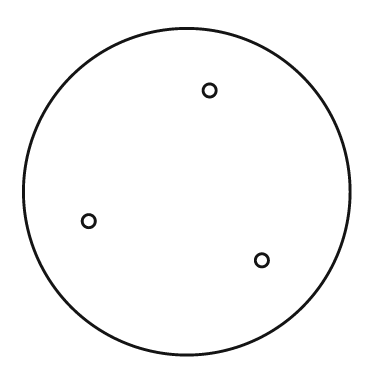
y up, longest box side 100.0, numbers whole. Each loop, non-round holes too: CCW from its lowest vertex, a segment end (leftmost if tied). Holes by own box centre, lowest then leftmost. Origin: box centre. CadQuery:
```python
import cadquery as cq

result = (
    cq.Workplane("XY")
    .moveTo(0.0, 0.0)
    .circle(50.0)
    .moveTo(23.0, -21.0)
    .circle(2.0)
    .moveTo(-30.0, -9.0)
    .circle(2.0)
    .moveTo(7.0, 31.0)
    .circle(2.0)
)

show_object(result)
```